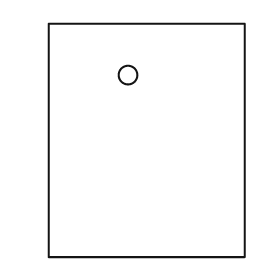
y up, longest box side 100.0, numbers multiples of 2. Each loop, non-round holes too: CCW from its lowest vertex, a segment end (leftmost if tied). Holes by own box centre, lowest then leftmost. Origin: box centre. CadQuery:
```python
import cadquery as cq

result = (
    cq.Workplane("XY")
    .moveTo(-42.0, -50.0)
    .lineTo(42.0, -50.0)
    .lineTo(42.0, 50.0)
    .lineTo(-42.0, 50.0)
    .close()
    .moveTo(-8.0, 28.0)
    .circle(4.0)
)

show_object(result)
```